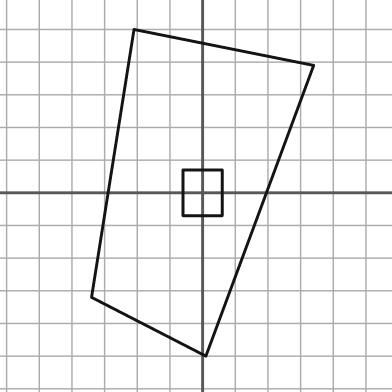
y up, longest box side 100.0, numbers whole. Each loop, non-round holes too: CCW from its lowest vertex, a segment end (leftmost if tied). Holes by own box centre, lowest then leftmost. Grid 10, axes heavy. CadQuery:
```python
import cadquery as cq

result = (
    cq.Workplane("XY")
    .moveTo(1.0, -50.0)
    .lineTo(34.0, 39.0)
    .lineTo(-21.0, 50.0)
    .lineTo(-34.0, -32.0)
    .close()
    .moveTo(-6.0, -7.0)
    .lineTo(6.0, -7.0)
    .lineTo(6.0, 7.0)
    .lineTo(-6.0, 7.0)
    .close()
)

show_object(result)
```